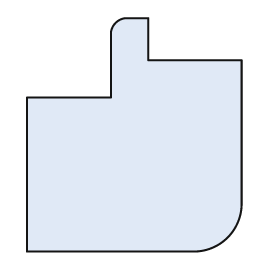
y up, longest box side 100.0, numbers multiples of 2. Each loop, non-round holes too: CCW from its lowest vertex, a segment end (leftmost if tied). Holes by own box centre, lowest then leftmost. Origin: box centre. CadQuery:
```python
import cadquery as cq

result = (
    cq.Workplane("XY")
    .moveTo(-46.0, -50.0)
    .lineTo(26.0, -50.0)
    .threePointArc((40.0, -44.0), (46.0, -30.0))
    .lineTo(46.0, 32.0)
    .lineTo(6.0, 32.0)
    .lineTo(6.0, 50.0)
    .lineTo(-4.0, 50.0)
    .threePointArc((-8.0, 48.0), (-10.0, 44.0))
    .lineTo(-10.0, 16.0)
    .lineTo(-46.0, 16.0)
    .close()
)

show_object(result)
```